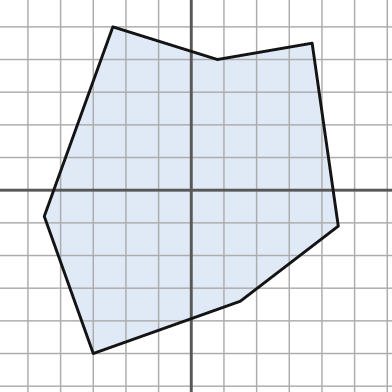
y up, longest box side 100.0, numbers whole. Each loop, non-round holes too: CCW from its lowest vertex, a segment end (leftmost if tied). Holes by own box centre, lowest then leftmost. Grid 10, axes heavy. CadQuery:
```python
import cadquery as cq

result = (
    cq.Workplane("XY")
    .moveTo(-30.0, -50.0)
    .lineTo(15.0, -34.0)
    .lineTo(45.0, -11.0)
    .lineTo(37.0, 45.0)
    .lineTo(8.0, 40.0)
    .lineTo(-24.0, 50.0)
    .lineTo(-45.0, -8.0)
    .close()
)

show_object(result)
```